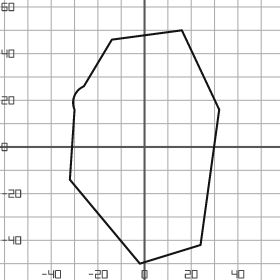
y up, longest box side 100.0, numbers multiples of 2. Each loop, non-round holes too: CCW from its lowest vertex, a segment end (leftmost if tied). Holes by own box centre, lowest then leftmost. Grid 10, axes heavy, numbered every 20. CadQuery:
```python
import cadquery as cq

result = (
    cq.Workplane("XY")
    .moveTo(-2.0, -50.0)
    .lineTo(24.0, -42.0)
    .lineTo(32.0, 16.0)
    .lineTo(16.0, 50.0)
    .lineTo(-14.0, 46.0)
    .lineTo(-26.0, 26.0)
    .threePointArc((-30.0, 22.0), (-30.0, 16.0))
    .lineTo(-32.0, -14.0)
    .close()
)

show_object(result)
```